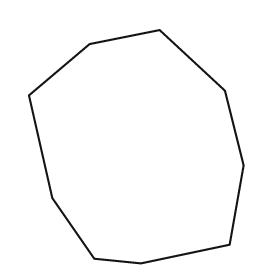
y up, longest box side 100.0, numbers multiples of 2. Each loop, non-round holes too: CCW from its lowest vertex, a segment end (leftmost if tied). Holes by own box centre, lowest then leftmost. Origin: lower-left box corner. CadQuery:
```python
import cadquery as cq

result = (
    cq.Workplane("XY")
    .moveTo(48.0, 0.0)
    .lineTo(86.0, 8.0)
    .lineTo(92.0, 42.0)
    .lineTo(84.0, 74.0)
    .lineTo(56.0, 100.0)
    .lineTo(26.0, 94.0)
    .lineTo(0.0, 72.0)
    .lineTo(10.0, 28.0)
    .lineTo(28.0, 2.0)
    .close()
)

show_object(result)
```